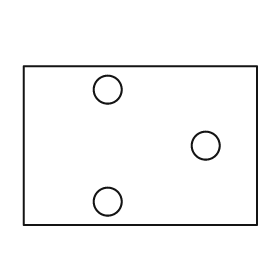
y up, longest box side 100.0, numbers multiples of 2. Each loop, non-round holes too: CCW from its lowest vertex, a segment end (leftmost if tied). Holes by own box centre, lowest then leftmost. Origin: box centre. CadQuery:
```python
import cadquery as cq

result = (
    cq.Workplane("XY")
    .moveTo(-50.0, -34.0)
    .lineTo(50.0, -34.0)
    .lineTo(50.0, 34.0)
    .lineTo(-50.0, 34.0)
    .close()
    .moveTo(-14.0, -24.0)
    .circle(6.0)
    .moveTo(28.0, 0.0)
    .circle(6.0)
    .moveTo(-14.0, 24.0)
    .circle(6.0)
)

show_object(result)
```